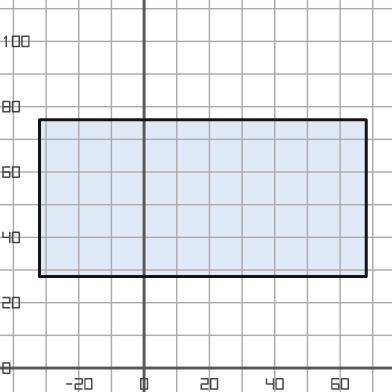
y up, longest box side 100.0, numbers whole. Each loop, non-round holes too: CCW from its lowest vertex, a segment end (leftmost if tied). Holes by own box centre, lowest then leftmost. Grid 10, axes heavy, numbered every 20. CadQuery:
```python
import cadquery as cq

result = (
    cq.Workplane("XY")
    .moveTo(-32.0, 28.0)
    .lineTo(68.0, 28.0)
    .lineTo(68.0, 76.0)
    .lineTo(-32.0, 76.0)
    .close()
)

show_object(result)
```